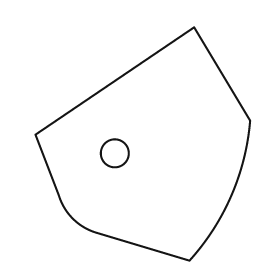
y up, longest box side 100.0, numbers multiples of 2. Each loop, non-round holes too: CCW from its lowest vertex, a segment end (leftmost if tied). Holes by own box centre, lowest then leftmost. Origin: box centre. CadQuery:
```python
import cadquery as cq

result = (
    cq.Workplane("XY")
    .moveTo(20.0, -50.0)
    .threePointArc((38.0, -22.0), (46.0, 10.0))
    .lineTo(22.0, 50.0)
    .lineTo(-46.0, 4.0)
    .lineTo(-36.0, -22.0)
    .threePointArc((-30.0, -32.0), (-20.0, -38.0))
    .close()
    .moveTo(-12.0, -4.0)
    .circle(6.0)
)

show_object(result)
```